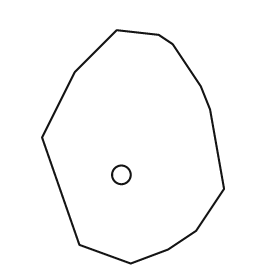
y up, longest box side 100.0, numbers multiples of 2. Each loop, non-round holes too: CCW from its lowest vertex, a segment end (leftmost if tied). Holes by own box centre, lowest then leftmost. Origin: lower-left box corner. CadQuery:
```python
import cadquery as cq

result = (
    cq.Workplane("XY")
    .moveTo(38.0, 0.0)
    .lineTo(54.0, 6.0)
    .lineTo(66.0, 14.0)
    .lineTo(78.0, 32.0)
    .lineTo(72.0, 66.0)
    .lineTo(68.0, 76.0)
    .lineTo(56.0, 94.0)
    .lineTo(50.0, 98.0)
    .lineTo(32.0, 100.0)
    .lineTo(14.0, 82.0)
    .lineTo(0.0, 54.0)
    .lineTo(16.0, 8.0)
    .close()
    .moveTo(34.0, 38.0)
    .circle(4.0)
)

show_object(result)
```